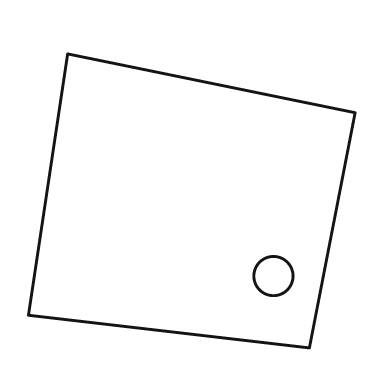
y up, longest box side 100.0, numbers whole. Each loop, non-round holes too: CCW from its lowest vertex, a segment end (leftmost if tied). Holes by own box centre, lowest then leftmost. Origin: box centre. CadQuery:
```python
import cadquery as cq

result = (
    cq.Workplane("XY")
    .moveTo(36.0, -45.0)
    .lineTo(50.0, 27.0)
    .lineTo(-38.0, 45.0)
    .lineTo(-50.0, -35.0)
    .close()
    .moveTo(25.0, -23.0)
    .circle(6.0)
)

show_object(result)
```